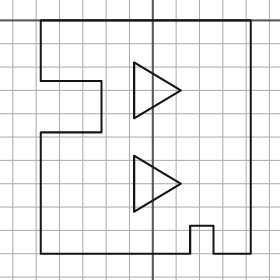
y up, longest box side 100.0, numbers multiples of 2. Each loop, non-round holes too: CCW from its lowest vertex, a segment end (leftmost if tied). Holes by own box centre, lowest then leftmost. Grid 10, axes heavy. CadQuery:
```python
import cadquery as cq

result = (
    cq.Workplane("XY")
    .moveTo(-48.0, -100.0)
    .lineTo(16.0, -100.0)
    .lineTo(16.0, -88.0)
    .lineTo(26.0, -88.0)
    .lineTo(26.0, -100.0)
    .lineTo(42.0, -100.0)
    .lineTo(42.0, 0.0)
    .lineTo(-48.0, 0.0)
    .lineTo(-48.0, -26.0)
    .lineTo(-22.0, -26.0)
    .lineTo(-22.0, -48.0)
    .lineTo(-48.0, -48.0)
    .close()
    .moveTo(-8.0, -82.0)
    .lineTo(12.0, -70.0)
    .lineTo(-8.0, -58.0)
    .close()
    .moveTo(-8.0, -42.0)
    .lineTo(12.0, -30.0)
    .lineTo(-8.0, -18.0)
    .close()
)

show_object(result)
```